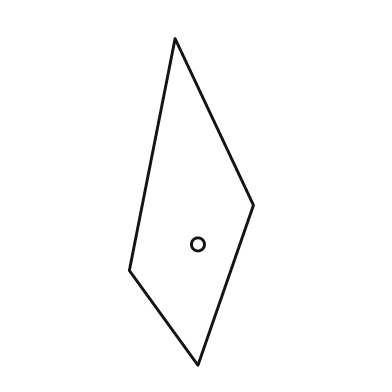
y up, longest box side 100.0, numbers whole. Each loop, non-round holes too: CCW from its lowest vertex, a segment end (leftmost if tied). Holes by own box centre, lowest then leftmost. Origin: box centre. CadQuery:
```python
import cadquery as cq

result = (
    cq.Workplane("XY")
    .moveTo(2.0, -50.0)
    .lineTo(19.0, -1.0)
    .lineTo(-5.0, 50.0)
    .lineTo(-19.0, -21.0)
    .close()
    .moveTo(2.0, -13.0)
    .circle(2.0)
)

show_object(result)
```